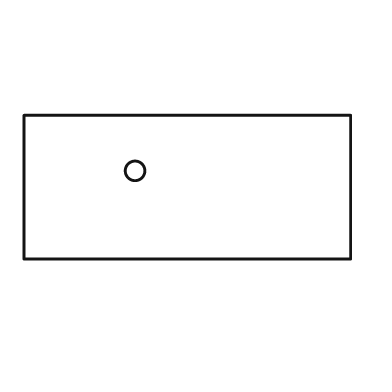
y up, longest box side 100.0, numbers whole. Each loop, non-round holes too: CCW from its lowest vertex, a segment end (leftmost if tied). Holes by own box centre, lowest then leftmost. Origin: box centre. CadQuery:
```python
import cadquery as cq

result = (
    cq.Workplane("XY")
    .moveTo(-50.0, -22.0)
    .lineTo(50.0, -22.0)
    .lineTo(50.0, 22.0)
    .lineTo(-50.0, 22.0)
    .close()
    .moveTo(-16.0, 5.0)
    .circle(3.0)
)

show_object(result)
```